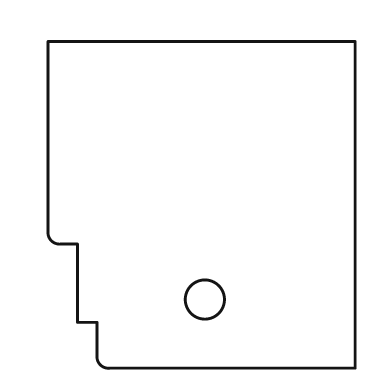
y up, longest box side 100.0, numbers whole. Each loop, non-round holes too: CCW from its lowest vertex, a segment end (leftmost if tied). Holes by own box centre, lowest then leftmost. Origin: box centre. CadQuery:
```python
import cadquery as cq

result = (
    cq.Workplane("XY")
    .moveTo(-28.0, -50.0)
    .lineTo(47.0, -50.0)
    .lineTo(47.0, 50.0)
    .lineTo(-47.0, 50.0)
    .lineTo(-47.0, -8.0)
    .threePointArc((-46.0, -11.0), (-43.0, -12.0))
    .lineTo(-38.0, -12.0)
    .lineTo(-38.0, -36.0)
    .lineTo(-32.0, -36.0)
    .lineTo(-32.0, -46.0)
    .threePointArc((-31.0, -49.0), (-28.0, -50.0))
    .close()
    .moveTo(1.0, -29.0)
    .circle(6.0)
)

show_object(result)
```